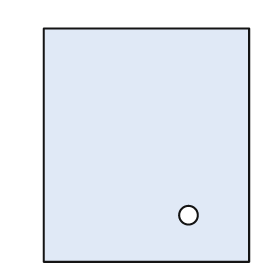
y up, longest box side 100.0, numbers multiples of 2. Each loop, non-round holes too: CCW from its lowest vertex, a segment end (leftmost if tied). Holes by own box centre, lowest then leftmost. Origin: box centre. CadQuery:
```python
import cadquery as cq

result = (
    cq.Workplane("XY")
    .moveTo(-44.0, -50.0)
    .lineTo(44.0, -50.0)
    .lineTo(44.0, 50.0)
    .lineTo(-44.0, 50.0)
    .close()
    .moveTo(18.0, -30.0)
    .circle(4.0)
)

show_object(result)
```